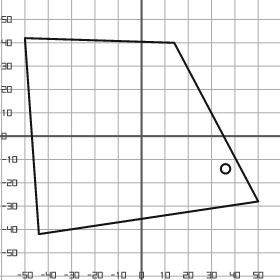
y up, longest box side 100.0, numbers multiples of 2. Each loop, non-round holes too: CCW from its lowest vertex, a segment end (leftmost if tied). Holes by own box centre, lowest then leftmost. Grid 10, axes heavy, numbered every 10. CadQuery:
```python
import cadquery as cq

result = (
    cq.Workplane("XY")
    .moveTo(-44.0, -42.0)
    .lineTo(50.0, -28.0)
    .lineTo(14.0, 40.0)
    .lineTo(-50.0, 42.0)
    .close()
    .moveTo(36.0, -14.0)
    .circle(2.0)
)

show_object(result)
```